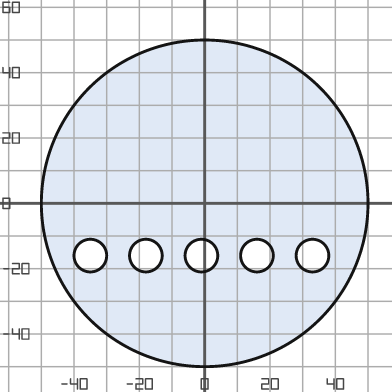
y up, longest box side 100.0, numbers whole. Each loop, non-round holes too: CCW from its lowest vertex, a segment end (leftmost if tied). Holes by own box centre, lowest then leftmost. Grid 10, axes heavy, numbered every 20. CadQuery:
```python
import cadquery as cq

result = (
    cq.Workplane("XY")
    .moveTo(0.0, 0.0)
    .circle(50.0)
    .moveTo(-35.0, -16.0)
    .circle(5.0)
    .moveTo(-18.0, -16.0)
    .circle(5.0)
    .moveTo(-1.0, -16.0)
    .circle(5.0)
    .moveTo(16.0, -16.0)
    .circle(5.0)
    .moveTo(33.0, -16.0)
    .circle(5.0)
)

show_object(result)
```